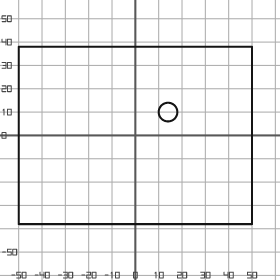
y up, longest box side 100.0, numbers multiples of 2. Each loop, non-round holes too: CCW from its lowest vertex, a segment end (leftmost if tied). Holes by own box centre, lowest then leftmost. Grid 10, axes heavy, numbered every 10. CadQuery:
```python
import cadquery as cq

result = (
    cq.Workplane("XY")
    .moveTo(-50.0, -38.0)
    .lineTo(50.0, -38.0)
    .lineTo(50.0, 38.0)
    .lineTo(-50.0, 38.0)
    .close()
    .moveTo(14.0, 10.0)
    .circle(4.0)
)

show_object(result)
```